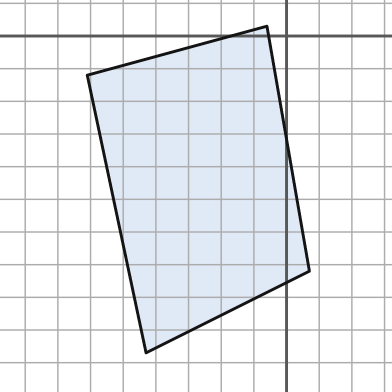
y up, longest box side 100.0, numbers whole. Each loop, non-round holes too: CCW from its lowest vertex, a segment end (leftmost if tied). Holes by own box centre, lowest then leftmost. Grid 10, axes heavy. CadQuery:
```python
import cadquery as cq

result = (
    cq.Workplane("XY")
    .moveTo(-43.0, -97.0)
    .lineTo(7.0, -72.0)
    .lineTo(-6.0, 3.0)
    .lineTo(-61.0, -12.0)
    .close()
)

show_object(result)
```